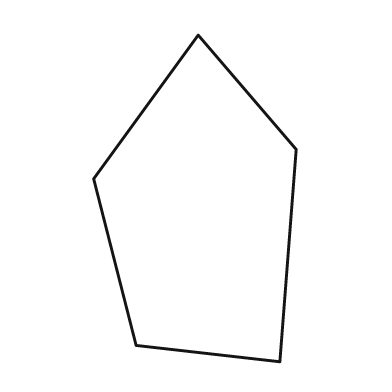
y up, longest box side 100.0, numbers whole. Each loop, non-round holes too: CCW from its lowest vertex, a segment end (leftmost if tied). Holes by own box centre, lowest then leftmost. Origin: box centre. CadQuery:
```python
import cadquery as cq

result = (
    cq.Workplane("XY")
    .moveTo(26.0, -50.0)
    .lineTo(31.0, 15.0)
    .lineTo(1.0, 50.0)
    .lineTo(-31.0, 6.0)
    .lineTo(-18.0, -45.0)
    .close()
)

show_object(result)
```